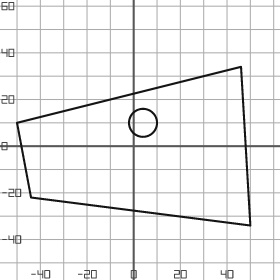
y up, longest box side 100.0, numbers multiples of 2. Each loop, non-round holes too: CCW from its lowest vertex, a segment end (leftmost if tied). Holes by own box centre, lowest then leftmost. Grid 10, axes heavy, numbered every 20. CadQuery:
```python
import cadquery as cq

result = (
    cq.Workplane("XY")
    .moveTo(50.0, -34.0)
    .lineTo(46.0, 34.0)
    .lineTo(-50.0, 10.0)
    .lineTo(-44.0, -22.0)
    .close()
    .moveTo(4.0, 10.0)
    .circle(6.0)
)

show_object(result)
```